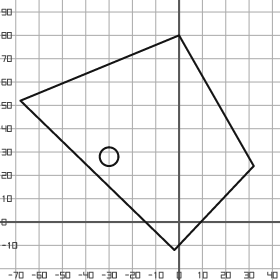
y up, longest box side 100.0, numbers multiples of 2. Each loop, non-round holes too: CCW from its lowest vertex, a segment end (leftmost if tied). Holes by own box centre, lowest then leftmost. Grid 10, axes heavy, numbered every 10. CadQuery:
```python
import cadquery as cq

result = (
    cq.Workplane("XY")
    .moveTo(-2.0, -12.0)
    .lineTo(32.0, 24.0)
    .lineTo(0.0, 80.0)
    .lineTo(-68.0, 52.0)
    .close()
    .moveTo(-30.0, 28.0)
    .circle(4.0)
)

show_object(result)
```